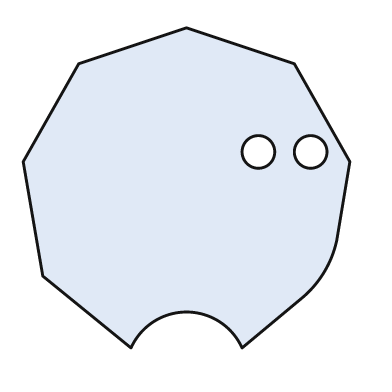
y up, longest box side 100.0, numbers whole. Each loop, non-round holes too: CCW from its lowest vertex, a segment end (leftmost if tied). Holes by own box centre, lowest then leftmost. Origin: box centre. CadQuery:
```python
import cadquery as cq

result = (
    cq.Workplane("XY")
    .moveTo(-17.0, -49.0)
    .threePointArc((0.0, -38.0), (17.0, -49.0))
    .lineTo(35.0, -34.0)
    .threePointArc((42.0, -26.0), (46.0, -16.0))
    .lineTo(50.0, 8.0)
    .lineTo(33.0, 38.0)
    .lineTo(0.0, 49.0)
    .lineTo(-33.0, 38.0)
    .lineTo(-50.0, 8.0)
    .lineTo(-44.0, -27.0)
    .close()
    .moveTo(22.0, 11.0)
    .circle(5.0)
    .moveTo(38.0, 11.0)
    .circle(5.0)
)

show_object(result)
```